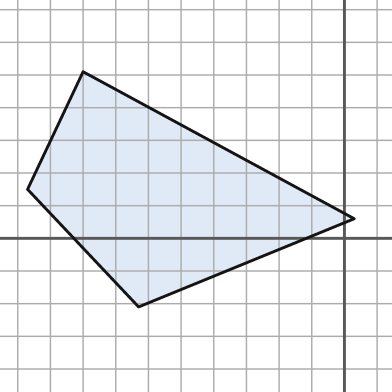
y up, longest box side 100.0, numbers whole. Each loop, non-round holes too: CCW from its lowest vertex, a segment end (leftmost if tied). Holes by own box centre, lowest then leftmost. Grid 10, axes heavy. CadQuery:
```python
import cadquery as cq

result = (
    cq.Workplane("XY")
    .moveTo(-63.0, -21.0)
    .lineTo(3.0, 6.0)
    .lineTo(-80.0, 51.0)
    .lineTo(-97.0, 15.0)
    .close()
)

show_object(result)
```